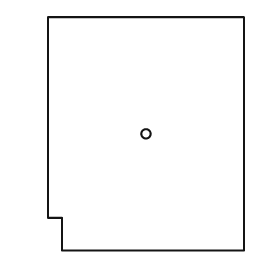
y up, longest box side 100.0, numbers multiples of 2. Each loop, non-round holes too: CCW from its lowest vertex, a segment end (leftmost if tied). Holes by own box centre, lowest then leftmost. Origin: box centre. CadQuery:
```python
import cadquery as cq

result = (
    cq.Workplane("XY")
    .moveTo(-36.0, -50.0)
    .lineTo(42.0, -50.0)
    .lineTo(42.0, 50.0)
    .lineTo(-42.0, 50.0)
    .lineTo(-42.0, -36.0)
    .lineTo(-36.0, -36.0)
    .close()
    .moveTo(0.0, 0.0)
    .circle(2.0)
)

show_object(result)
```